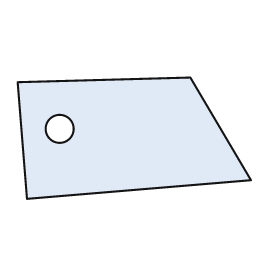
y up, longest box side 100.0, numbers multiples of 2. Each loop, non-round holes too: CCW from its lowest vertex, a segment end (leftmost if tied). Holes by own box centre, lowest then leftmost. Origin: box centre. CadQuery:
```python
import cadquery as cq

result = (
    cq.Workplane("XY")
    .moveTo(-46.0, -26.0)
    .lineTo(50.0, -18.0)
    .lineTo(24.0, 26.0)
    .lineTo(-50.0, 24.0)
    .close()
    .moveTo(-32.0, 4.0)
    .circle(6.0)
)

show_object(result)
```